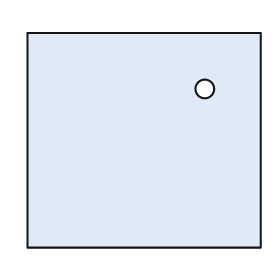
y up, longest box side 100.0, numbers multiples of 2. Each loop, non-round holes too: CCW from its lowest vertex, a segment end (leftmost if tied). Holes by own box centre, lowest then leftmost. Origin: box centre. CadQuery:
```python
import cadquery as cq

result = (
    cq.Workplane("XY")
    .moveTo(-50.0, -46.0)
    .lineTo(50.0, -46.0)
    .lineTo(50.0, 46.0)
    .lineTo(-50.0, 46.0)
    .close()
    .moveTo(26.0, 22.0)
    .circle(4.0)
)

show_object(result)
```